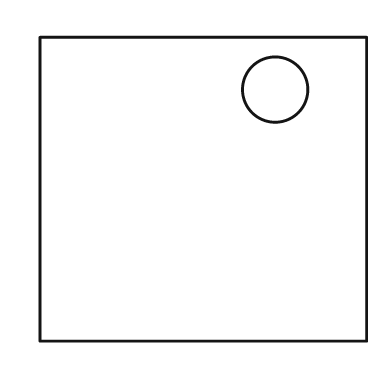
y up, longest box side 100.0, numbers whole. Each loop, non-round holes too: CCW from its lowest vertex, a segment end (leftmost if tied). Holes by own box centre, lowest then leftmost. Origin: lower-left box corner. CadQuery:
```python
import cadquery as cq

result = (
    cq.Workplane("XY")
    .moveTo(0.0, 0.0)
    .lineTo(100.0, 0.0)
    .lineTo(100.0, 93.0)
    .lineTo(0.0, 93.0)
    .close()
    .moveTo(72.0, 77.0)
    .circle(10.0)
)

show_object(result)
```